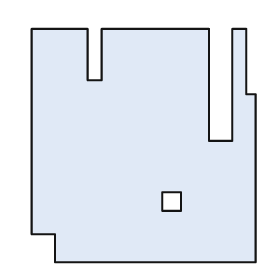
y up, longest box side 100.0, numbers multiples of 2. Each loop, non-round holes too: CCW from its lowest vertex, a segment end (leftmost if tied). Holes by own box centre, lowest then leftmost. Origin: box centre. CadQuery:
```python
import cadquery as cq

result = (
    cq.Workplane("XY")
    .moveTo(-38.0, -50.0)
    .lineTo(48.0, -50.0)
    .lineTo(48.0, 22.0)
    .lineTo(44.0, 22.0)
    .lineTo(44.0, 50.0)
    .lineTo(38.0, 50.0)
    .lineTo(38.0, 2.0)
    .lineTo(28.0, 2.0)
    .lineTo(28.0, 50.0)
    .lineTo(-18.0, 50.0)
    .lineTo(-18.0, 28.0)
    .lineTo(-24.0, 28.0)
    .lineTo(-24.0, 50.0)
    .lineTo(-48.0, 50.0)
    .lineTo(-48.0, -38.0)
    .lineTo(-38.0, -38.0)
    .close()
    .moveTo(8.0, -28.0)
    .lineTo(16.0, -28.0)
    .lineTo(16.0, -20.0)
    .lineTo(8.0, -20.0)
    .close()
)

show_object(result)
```